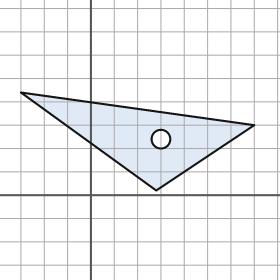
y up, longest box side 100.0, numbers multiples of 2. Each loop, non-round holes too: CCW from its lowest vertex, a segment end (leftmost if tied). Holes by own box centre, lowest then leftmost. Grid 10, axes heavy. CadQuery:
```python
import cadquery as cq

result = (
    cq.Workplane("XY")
    .moveTo(28.0, 2.0)
    .lineTo(70.0, 30.0)
    .lineTo(-30.0, 44.0)
    .close()
    .moveTo(30.0, 24.0)
    .circle(4.0)
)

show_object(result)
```